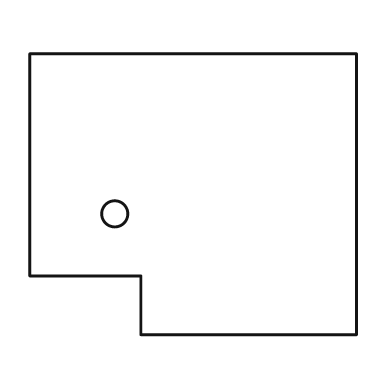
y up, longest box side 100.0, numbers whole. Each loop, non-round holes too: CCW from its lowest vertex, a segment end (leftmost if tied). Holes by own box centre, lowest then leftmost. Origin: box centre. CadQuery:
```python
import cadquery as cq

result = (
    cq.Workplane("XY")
    .moveTo(-16.0, -43.0)
    .lineTo(50.0, -43.0)
    .lineTo(50.0, 43.0)
    .lineTo(-50.0, 43.0)
    .lineTo(-50.0, -25.0)
    .lineTo(-16.0, -25.0)
    .close()
    .moveTo(-24.0, -6.0)
    .circle(4.0)
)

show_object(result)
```